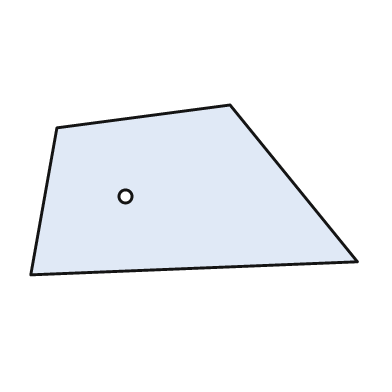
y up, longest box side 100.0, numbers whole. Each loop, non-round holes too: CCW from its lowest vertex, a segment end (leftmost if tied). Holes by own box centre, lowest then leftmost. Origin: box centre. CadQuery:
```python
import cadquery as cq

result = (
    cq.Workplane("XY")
    .moveTo(-50.0, -26.0)
    .lineTo(50.0, -22.0)
    .lineTo(11.0, 26.0)
    .lineTo(-42.0, 19.0)
    .close()
    .moveTo(-21.0, -2.0)
    .circle(2.0)
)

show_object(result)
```